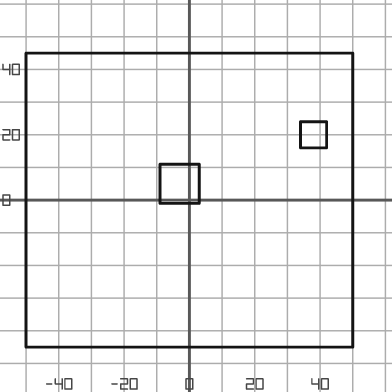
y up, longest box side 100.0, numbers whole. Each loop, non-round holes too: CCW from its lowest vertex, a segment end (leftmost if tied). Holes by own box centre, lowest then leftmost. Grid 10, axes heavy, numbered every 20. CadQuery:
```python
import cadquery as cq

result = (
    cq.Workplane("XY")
    .moveTo(-50.0, -45.0)
    .lineTo(50.0, -45.0)
    .lineTo(50.0, 45.0)
    .lineTo(-50.0, 45.0)
    .close()
    .moveTo(-9.0, -1.0)
    .lineTo(3.0, -1.0)
    .lineTo(3.0, 11.0)
    .lineTo(-9.0, 11.0)
    .close()
    .moveTo(34.0, 16.0)
    .lineTo(42.0, 16.0)
    .lineTo(42.0, 24.0)
    .lineTo(34.0, 24.0)
    .close()
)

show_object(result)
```